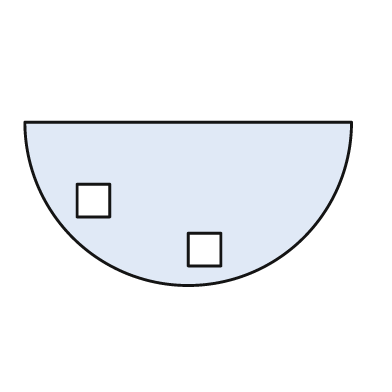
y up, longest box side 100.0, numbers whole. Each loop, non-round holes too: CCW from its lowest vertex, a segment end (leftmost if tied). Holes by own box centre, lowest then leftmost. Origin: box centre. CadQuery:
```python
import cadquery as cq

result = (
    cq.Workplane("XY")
    .moveTo(-50.0, 25.0)
    .threePointArc((0.0, -25.0), (50.0, 25.0))
    .close()
    .moveTo(0.0, -19.0)
    .lineTo(10.0, -19.0)
    .lineTo(10.0, -9.0)
    .lineTo(0.0, -9.0)
    .close()
    .moveTo(-34.0, -4.0)
    .lineTo(-24.0, -4.0)
    .lineTo(-24.0, 6.0)
    .lineTo(-34.0, 6.0)
    .close()
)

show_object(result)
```